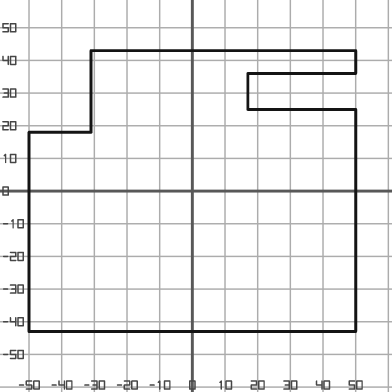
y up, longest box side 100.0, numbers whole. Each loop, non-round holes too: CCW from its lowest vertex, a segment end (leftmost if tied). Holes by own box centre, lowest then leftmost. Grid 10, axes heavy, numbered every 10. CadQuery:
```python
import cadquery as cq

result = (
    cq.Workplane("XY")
    .moveTo(-50.0, -43.0)
    .lineTo(50.0, -43.0)
    .lineTo(50.0, 25.0)
    .lineTo(17.0, 25.0)
    .lineTo(17.0, 36.0)
    .lineTo(50.0, 36.0)
    .lineTo(50.0, 43.0)
    .lineTo(-31.0, 43.0)
    .lineTo(-31.0, 18.0)
    .lineTo(-50.0, 18.0)
    .close()
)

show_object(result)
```